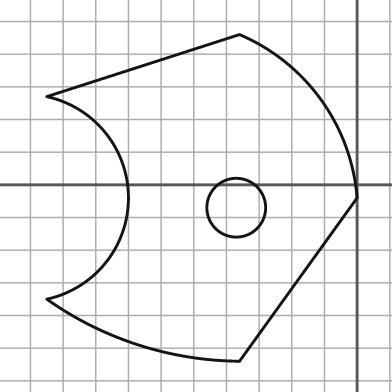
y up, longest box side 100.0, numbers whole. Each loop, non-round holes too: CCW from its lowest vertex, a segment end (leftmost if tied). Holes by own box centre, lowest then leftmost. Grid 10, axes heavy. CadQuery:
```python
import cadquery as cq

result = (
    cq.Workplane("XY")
    .moveTo(-36.0, -54.0)
    .lineTo(0.0, -4.0)
    .threePointArc((-11.0, 26.0), (-36.0, 46.0))
    .lineTo(-95.0, 27.0)
    .threePointArc((-70.0, -4.0), (-95.0, -35.0))
    .threePointArc((-67.0, -49.0), (-36.0, -54.0))
    .close()
    .moveTo(-37.0, -7.0)
    .circle(9.0)
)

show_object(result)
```